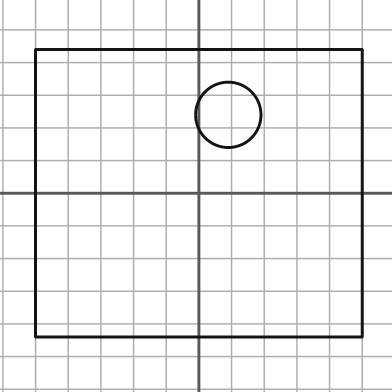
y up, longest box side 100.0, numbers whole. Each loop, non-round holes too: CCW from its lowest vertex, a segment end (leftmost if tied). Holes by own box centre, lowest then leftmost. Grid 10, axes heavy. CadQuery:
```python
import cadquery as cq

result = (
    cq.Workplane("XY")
    .moveTo(-50.0, -44.0)
    .lineTo(50.0, -44.0)
    .lineTo(50.0, 44.0)
    .lineTo(-50.0, 44.0)
    .close()
    .moveTo(9.0, 24.0)
    .circle(10.0)
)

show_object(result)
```